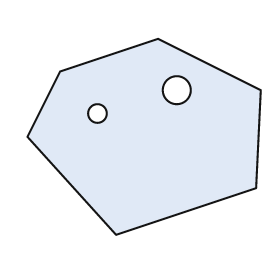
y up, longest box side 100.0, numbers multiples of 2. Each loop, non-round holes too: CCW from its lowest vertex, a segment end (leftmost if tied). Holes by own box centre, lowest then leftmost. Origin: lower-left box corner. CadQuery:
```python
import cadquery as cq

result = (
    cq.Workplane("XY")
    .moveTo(38.0, 0.0)
    .lineTo(98.0, 20.0)
    .lineTo(100.0, 62.0)
    .lineTo(56.0, 84.0)
    .lineTo(14.0, 70.0)
    .lineTo(0.0, 42.0)
    .close()
    .moveTo(30.0, 52.0)
    .circle(4.0)
    .moveTo(64.0, 62.0)
    .circle(6.0)
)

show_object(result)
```